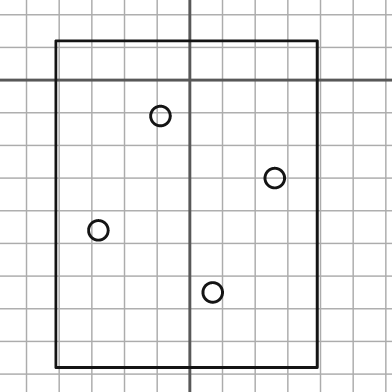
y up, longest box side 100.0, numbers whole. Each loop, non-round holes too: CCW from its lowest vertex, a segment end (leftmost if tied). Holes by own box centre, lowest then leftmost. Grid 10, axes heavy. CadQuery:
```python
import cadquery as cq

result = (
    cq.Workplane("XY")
    .moveTo(-41.0, -88.0)
    .lineTo(39.0, -88.0)
    .lineTo(39.0, 12.0)
    .lineTo(-41.0, 12.0)
    .close()
    .moveTo(7.0, -65.0)
    .circle(3.0)
    .moveTo(-28.0, -46.0)
    .circle(3.0)
    .moveTo(26.0, -30.0)
    .circle(3.0)
    .moveTo(-9.0, -11.0)
    .circle(3.0)
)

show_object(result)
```